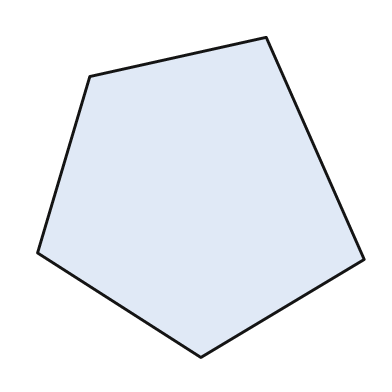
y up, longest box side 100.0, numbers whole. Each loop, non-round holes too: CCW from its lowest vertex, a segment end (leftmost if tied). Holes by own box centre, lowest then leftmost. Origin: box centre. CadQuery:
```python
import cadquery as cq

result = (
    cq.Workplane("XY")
    .moveTo(0.0, -49.0)
    .lineTo(50.0, -19.0)
    .lineTo(20.0, 49.0)
    .lineTo(-34.0, 37.0)
    .lineTo(-50.0, -17.0)
    .close()
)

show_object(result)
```